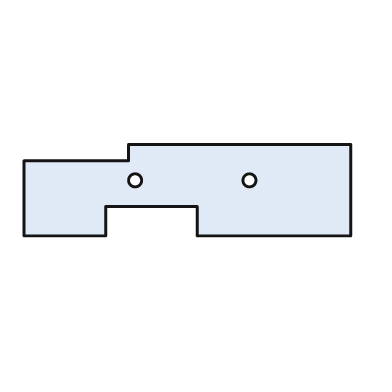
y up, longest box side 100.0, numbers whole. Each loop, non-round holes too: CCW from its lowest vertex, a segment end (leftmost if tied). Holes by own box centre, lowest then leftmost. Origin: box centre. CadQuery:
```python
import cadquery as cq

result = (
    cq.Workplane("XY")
    .moveTo(-50.0, -14.0)
    .lineTo(-25.0, -14.0)
    .lineTo(-25.0, -5.0)
    .lineTo(3.0, -5.0)
    .lineTo(3.0, -14.0)
    .lineTo(50.0, -14.0)
    .lineTo(50.0, 14.0)
    .lineTo(-18.0, 14.0)
    .lineTo(-18.0, 9.0)
    .lineTo(-50.0, 9.0)
    .close()
    .moveTo(-16.0, 3.0)
    .circle(2.0)
    .moveTo(19.0, 3.0)
    .circle(2.0)
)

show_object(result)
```